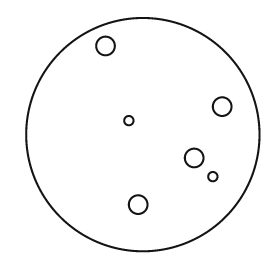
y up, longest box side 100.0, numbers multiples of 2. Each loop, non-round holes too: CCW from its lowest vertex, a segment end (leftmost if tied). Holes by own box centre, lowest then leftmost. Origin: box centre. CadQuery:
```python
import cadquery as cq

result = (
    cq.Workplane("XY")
    .moveTo(0.0, 0.0)
    .circle(50.0)
    .moveTo(-2.0, -30.0)
    .circle(4.0)
    .moveTo(30.0, -18.0)
    .circle(2.0)
    .moveTo(22.0, -10.0)
    .circle(4.0)
    .moveTo(-6.0, 6.0)
    .circle(2.0)
    .moveTo(34.0, 12.0)
    .circle(4.0)
    .moveTo(-16.0, 38.0)
    .circle(4.0)
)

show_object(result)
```